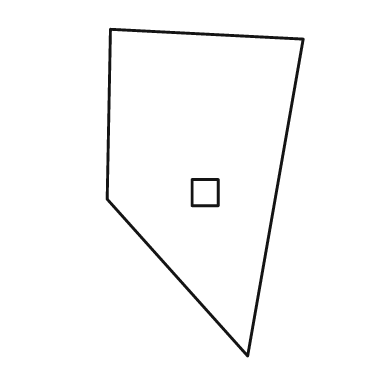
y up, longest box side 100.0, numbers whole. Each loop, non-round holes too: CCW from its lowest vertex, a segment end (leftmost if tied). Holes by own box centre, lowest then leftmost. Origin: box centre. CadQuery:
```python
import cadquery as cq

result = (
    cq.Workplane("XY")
    .moveTo(13.0, -50.0)
    .lineTo(30.0, 47.0)
    .lineTo(-29.0, 50.0)
    .lineTo(-30.0, -2.0)
    .close()
    .moveTo(-4.0, -4.0)
    .lineTo(4.0, -4.0)
    .lineTo(4.0, 4.0)
    .lineTo(-4.0, 4.0)
    .close()
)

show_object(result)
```